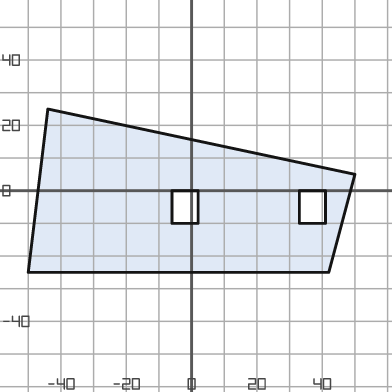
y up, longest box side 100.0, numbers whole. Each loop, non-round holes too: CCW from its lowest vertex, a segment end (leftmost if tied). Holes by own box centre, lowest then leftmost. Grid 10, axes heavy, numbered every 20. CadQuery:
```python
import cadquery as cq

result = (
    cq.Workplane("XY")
    .moveTo(-50.0, -25.0)
    .lineTo(42.0, -25.0)
    .lineTo(50.0, 5.0)
    .lineTo(-44.0, 25.0)
    .close()
    .moveTo(-6.0, -10.0)
    .lineTo(2.0, -10.0)
    .lineTo(2.0, 0.0)
    .lineTo(-6.0, 0.0)
    .close()
    .moveTo(33.0, -10.0)
    .lineTo(41.0, -10.0)
    .lineTo(41.0, 0.0)
    .lineTo(33.0, 0.0)
    .close()
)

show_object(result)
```